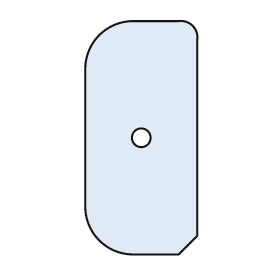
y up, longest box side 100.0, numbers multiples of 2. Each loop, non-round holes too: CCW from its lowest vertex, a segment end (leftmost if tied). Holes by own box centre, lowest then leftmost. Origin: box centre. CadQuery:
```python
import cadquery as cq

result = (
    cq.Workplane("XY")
    .moveTo(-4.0, -50.0)
    .lineTo(16.0, -50.0)
    .lineTo(24.0, -42.0)
    .lineTo(24.0, 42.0)
    .threePointArc((22.0, 48.0), (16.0, 50.0))
    .lineTo(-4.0, 50.0)
    .threePointArc((-18.0, 44.0), (-24.0, 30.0))
    .lineTo(-24.0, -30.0)
    .threePointArc((-18.0, -44.0), (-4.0, -50.0))
    .close()
    .moveTo(0.0, 0.0)
    .circle(4.0)
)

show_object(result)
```